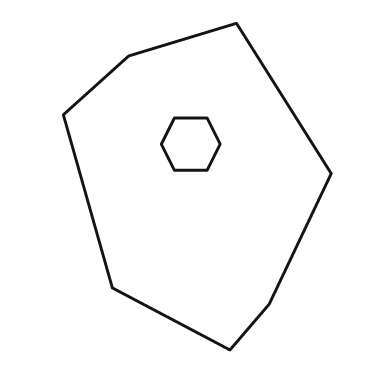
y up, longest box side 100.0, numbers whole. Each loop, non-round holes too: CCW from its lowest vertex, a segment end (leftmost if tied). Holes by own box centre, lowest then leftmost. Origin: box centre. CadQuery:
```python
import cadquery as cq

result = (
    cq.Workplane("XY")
    .moveTo(10.0, -50.0)
    .lineTo(22.0, -36.0)
    .lineTo(41.0, 4.0)
    .lineTo(12.0, 50.0)
    .lineTo(-21.0, 40.0)
    .lineTo(-41.0, 22.0)
    .lineTo(-26.0, -31.0)
    .close()
    .moveTo(-7.0, 5.0)
    .lineTo(3.0, 5.0)
    .lineTo(7.0, 13.0)
    .lineTo(3.0, 21.0)
    .lineTo(-7.0, 21.0)
    .lineTo(-11.0, 13.0)
    .close()
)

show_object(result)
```